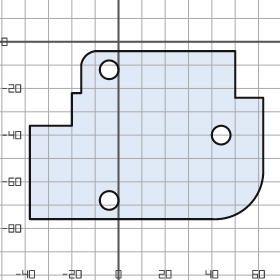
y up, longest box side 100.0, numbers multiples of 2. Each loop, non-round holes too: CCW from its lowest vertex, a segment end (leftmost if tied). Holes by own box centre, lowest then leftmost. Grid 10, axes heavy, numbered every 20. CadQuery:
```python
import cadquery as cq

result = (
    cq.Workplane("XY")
    .moveTo(-38.0, -76.0)
    .lineTo(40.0, -76.0)
    .threePointArc((56.0, -70.0), (62.0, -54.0))
    .lineTo(62.0, -24.0)
    .lineTo(50.0, -24.0)
    .lineTo(50.0, -4.0)
    .lineTo(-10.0, -4.0)
    .threePointArc((-14.0, -6.0), (-16.0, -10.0))
    .lineTo(-16.0, -22.0)
    .lineTo(-20.0, -22.0)
    .lineTo(-20.0, -36.0)
    .lineTo(-38.0, -36.0)
    .close()
    .moveTo(-4.0, -68.0)
    .circle(4.0)
    .moveTo(44.0, -40.0)
    .circle(4.0)
    .moveTo(-4.0, -12.0)
    .circle(4.0)
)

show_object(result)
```